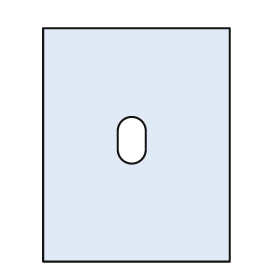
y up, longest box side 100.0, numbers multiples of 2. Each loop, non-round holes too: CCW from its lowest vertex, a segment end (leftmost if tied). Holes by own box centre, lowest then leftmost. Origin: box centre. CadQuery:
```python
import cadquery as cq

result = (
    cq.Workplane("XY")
    .moveTo(-40.0, -50.0)
    .lineTo(40.0, -50.0)
    .lineTo(40.0, 50.0)
    .lineTo(-40.0, 50.0)
    .close()
    .moveTo(-8.0, -2.0)
    .threePointArc((-2.0, -8.0), (4.0, -2.0))
    .lineTo(4.0, 6.0)
    .threePointArc((-2.0, 12.0), (-8.0, 6.0))
    .close()
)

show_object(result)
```